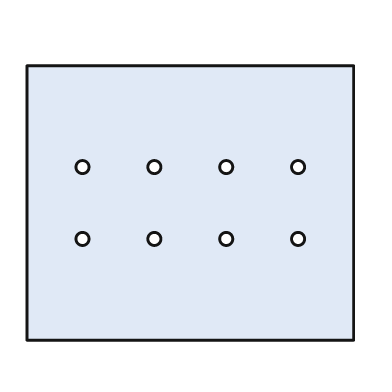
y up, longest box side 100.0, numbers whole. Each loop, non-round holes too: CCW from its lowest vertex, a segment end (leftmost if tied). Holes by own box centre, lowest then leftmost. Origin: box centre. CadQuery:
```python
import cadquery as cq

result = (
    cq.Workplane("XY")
    .moveTo(-50.0, -42.0)
    .lineTo(50.0, -42.0)
    .lineTo(50.0, 42.0)
    .lineTo(-50.0, 42.0)
    .close()
    .moveTo(-33.0, -11.0)
    .circle(2.0)
    .moveTo(-11.0, -11.0)
    .circle(2.0)
    .moveTo(11.0, -11.0)
    .circle(2.0)
    .moveTo(33.0, -11.0)
    .circle(2.0)
    .moveTo(-33.0, 11.0)
    .circle(2.0)
    .moveTo(-11.0, 11.0)
    .circle(2.0)
    .moveTo(11.0, 11.0)
    .circle(2.0)
    .moveTo(33.0, 11.0)
    .circle(2.0)
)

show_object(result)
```